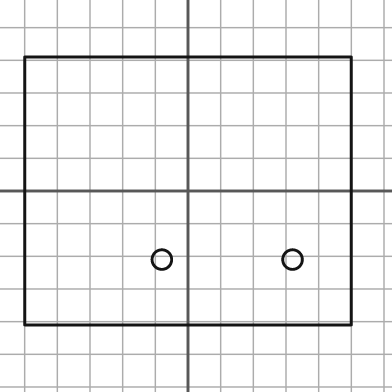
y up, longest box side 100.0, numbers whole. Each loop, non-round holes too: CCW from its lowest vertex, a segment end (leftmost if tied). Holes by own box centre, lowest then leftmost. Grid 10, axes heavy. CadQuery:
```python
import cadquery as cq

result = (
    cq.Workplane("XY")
    .moveTo(-50.0, -41.0)
    .lineTo(50.0, -41.0)
    .lineTo(50.0, 41.0)
    .lineTo(-50.0, 41.0)
    .close()
    .moveTo(-8.0, -21.0)
    .circle(3.0)
    .moveTo(32.0, -21.0)
    .circle(3.0)
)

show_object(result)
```